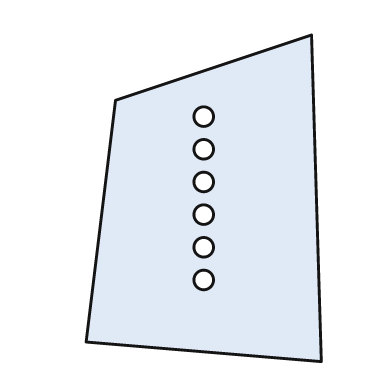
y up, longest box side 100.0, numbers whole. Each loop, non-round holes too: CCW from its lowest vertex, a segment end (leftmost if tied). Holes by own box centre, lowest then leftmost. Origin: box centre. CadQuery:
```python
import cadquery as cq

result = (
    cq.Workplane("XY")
    .moveTo(36.0, -50.0)
    .lineTo(33.0, 50.0)
    .lineTo(-27.0, 30.0)
    .lineTo(-36.0, -44.0)
    .close()
    .moveTo(0.0, -25.0)
    .circle(3.0)
    .moveTo(0.0, -15.0)
    .circle(3.0)
    .moveTo(0.0, -5.0)
    .circle(3.0)
    .moveTo(0.0, 5.0)
    .circle(3.0)
    .moveTo(0.0, 15.0)
    .circle(3.0)
    .moveTo(0.0, 25.0)
    .circle(3.0)
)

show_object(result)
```